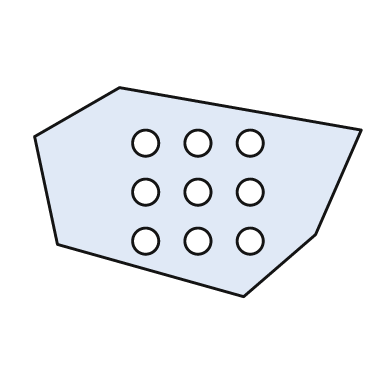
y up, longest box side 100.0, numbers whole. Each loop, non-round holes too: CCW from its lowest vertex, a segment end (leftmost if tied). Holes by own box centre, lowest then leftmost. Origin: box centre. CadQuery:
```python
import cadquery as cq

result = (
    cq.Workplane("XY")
    .moveTo(14.0, -32.0)
    .lineTo(36.0, -13.0)
    .lineTo(50.0, 19.0)
    .lineTo(-24.0, 32.0)
    .lineTo(-50.0, 17.0)
    .lineTo(-43.0, -16.0)
    .close()
    .moveTo(-16.0, -15.0)
    .circle(4.0)
    .moveTo(0.0, -15.0)
    .circle(4.0)
    .moveTo(16.0, -15.0)
    .circle(4.0)
    .moveTo(-16.0, 0.0)
    .circle(4.0)
    .moveTo(0.0, 0.0)
    .circle(4.0)
    .moveTo(16.0, 0.0)
    .circle(4.0)
    .moveTo(-16.0, 15.0)
    .circle(4.0)
    .moveTo(0.0, 15.0)
    .circle(4.0)
    .moveTo(16.0, 15.0)
    .circle(4.0)
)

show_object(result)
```